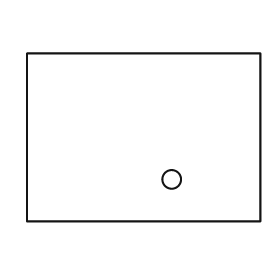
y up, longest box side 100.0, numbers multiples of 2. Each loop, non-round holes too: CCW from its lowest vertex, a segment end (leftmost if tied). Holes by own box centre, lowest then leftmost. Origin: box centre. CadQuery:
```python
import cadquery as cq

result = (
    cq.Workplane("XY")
    .moveTo(-50.0, -36.0)
    .lineTo(50.0, -36.0)
    .lineTo(50.0, 36.0)
    .lineTo(-50.0, 36.0)
    .close()
    .moveTo(12.0, -18.0)
    .circle(4.0)
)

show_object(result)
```